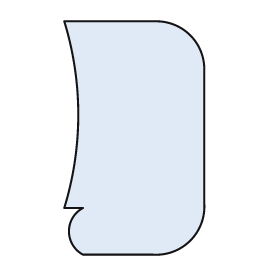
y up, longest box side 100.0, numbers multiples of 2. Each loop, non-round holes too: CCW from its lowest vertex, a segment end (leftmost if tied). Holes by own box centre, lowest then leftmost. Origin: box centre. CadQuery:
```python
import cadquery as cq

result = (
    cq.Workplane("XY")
    .moveTo(-22.0, -50.0)
    .lineTo(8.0, -50.0)
    .threePointArc((24.0, -44.0), (30.0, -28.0))
    .lineTo(30.0, 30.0)
    .threePointArc((24.0, 44.0), (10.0, 50.0))
    .lineTo(-30.0, 50.0)
    .threePointArc((-24.0, 10.0), (-30.0, -30.0))
    .lineTo(-22.0, -30.0)
    .threePointArc((-28.0, -40.0), (-22.0, -50.0))
    .close()
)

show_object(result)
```